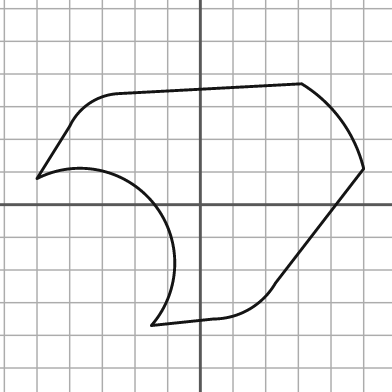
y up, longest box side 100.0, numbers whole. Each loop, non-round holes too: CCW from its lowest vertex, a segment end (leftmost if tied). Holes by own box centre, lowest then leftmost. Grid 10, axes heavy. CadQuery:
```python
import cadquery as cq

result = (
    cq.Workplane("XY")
    .moveTo(-15.0, -37.0)
    .lineTo(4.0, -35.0)
    .threePointArc((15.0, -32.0), (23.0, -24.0))
    .lineTo(50.0, 11.0)
    .threePointArc((43.0, 26.0), (31.0, 37.0))
    .lineTo(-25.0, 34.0)
    .threePointArc((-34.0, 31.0), (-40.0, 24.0))
    .lineTo(-50.0, 8.0)
    .threePointArc((-14.0, 0.0), (-15.0, -37.0))
    .close()
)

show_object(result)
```